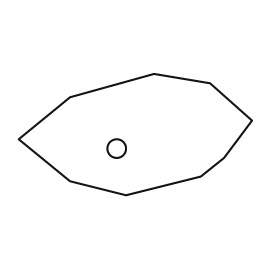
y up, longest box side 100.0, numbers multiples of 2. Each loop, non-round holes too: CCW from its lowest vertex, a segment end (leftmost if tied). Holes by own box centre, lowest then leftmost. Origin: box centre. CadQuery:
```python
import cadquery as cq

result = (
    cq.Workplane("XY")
    .moveTo(-4.0, -26.0)
    .lineTo(28.0, -18.0)
    .lineTo(38.0, -10.0)
    .lineTo(50.0, 6.0)
    .lineTo(32.0, 22.0)
    .lineTo(8.0, 26.0)
    .lineTo(-28.0, 16.0)
    .lineTo(-50.0, -2.0)
    .lineTo(-28.0, -20.0)
    .close()
    .moveTo(-8.0, -6.0)
    .circle(4.0)
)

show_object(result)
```